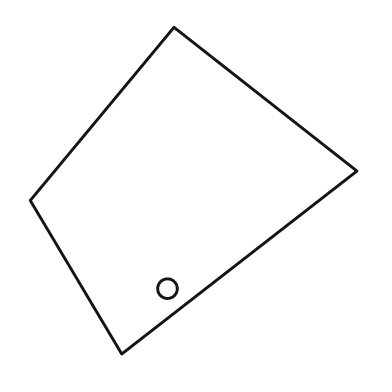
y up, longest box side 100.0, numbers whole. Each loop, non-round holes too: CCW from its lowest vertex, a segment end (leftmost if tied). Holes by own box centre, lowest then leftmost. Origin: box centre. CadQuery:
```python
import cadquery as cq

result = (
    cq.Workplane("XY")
    .moveTo(-22.0, -50.0)
    .lineTo(50.0, 6.0)
    .lineTo(-6.0, 50.0)
    .lineTo(-50.0, -3.0)
    .close()
    .moveTo(-8.0, -30.0)
    .circle(3.0)
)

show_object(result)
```